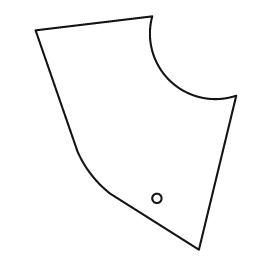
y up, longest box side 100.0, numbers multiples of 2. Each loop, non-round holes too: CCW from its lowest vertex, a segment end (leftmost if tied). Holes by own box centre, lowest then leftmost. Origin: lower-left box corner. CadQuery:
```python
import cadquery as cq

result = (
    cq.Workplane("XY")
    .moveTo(70.0, 0.0)
    .lineTo(86.0, 66.0)
    .threePointArc((58.0, 72.0), (50.0, 100.0))
    .lineTo(0.0, 94.0)
    .lineTo(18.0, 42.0)
    .threePointArc((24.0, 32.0), (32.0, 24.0))
    .close()
    .moveTo(52.0, 22.0)
    .circle(2.0)
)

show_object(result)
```